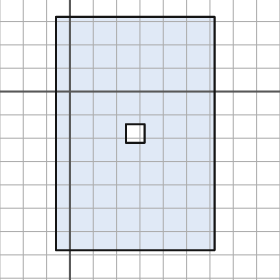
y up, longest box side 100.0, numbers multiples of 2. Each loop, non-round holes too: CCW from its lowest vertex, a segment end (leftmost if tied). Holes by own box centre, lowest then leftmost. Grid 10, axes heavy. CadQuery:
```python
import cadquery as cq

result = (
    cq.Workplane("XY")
    .moveTo(-6.0, -68.0)
    .lineTo(62.0, -68.0)
    .lineTo(62.0, 32.0)
    .lineTo(-6.0, 32.0)
    .close()
    .moveTo(24.0, -22.0)
    .lineTo(32.0, -22.0)
    .lineTo(32.0, -14.0)
    .lineTo(24.0, -14.0)
    .close()
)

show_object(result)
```